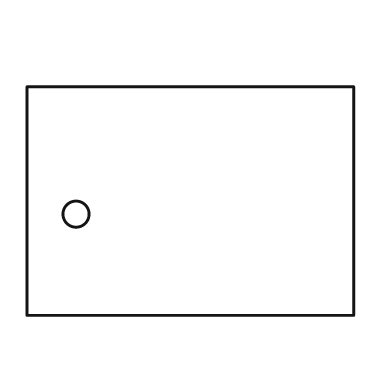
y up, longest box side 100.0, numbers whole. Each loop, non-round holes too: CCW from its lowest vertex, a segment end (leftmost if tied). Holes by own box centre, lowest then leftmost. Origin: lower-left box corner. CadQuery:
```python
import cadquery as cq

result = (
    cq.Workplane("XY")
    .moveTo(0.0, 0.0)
    .lineTo(100.0, 0.0)
    .lineTo(100.0, 70.0)
    .lineTo(0.0, 70.0)
    .close()
    .moveTo(15.0, 31.0)
    .circle(4.0)
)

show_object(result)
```